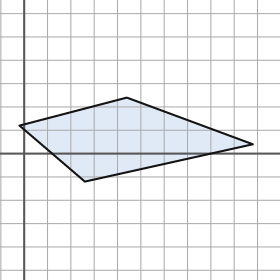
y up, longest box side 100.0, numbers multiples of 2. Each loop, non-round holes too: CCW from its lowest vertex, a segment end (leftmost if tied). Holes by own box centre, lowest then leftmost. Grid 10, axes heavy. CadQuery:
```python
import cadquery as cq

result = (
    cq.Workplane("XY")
    .moveTo(26.0, -12.0)
    .lineTo(98.0, 4.0)
    .lineTo(44.0, 24.0)
    .lineTo(-2.0, 12.0)
    .close()
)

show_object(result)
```